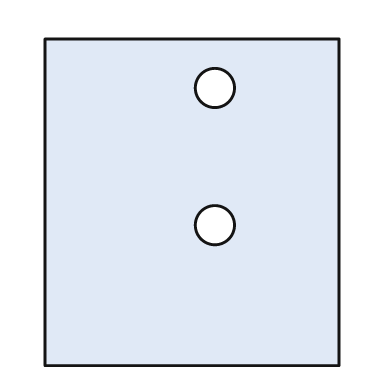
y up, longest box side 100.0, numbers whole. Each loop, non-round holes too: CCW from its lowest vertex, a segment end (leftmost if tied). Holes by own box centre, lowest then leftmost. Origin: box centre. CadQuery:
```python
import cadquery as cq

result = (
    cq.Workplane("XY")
    .moveTo(-45.0, -50.0)
    .lineTo(45.0, -50.0)
    .lineTo(45.0, 50.0)
    .lineTo(-45.0, 50.0)
    .close()
    .moveTo(7.0, -7.0)
    .circle(6.0)
    .moveTo(7.0, 35.0)
    .circle(6.0)
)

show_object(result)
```